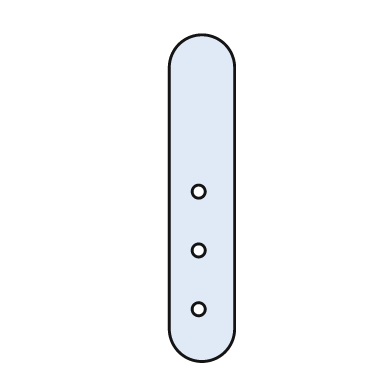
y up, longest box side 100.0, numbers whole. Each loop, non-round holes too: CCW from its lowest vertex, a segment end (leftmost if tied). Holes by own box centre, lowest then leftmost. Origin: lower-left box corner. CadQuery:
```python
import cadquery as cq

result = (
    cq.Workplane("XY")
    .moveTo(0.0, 10.0)
    .threePointArc((10.0, 0.0), (20.0, 10.0))
    .lineTo(20.0, 90.0)
    .threePointArc((10.0, 100.0), (0.0, 90.0))
    .close()
    .moveTo(9.0, 16.0)
    .circle(2.0)
    .moveTo(9.0, 34.0)
    .circle(2.0)
    .moveTo(9.0, 52.0)
    .circle(2.0)
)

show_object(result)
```